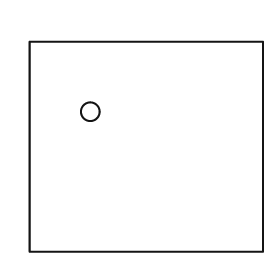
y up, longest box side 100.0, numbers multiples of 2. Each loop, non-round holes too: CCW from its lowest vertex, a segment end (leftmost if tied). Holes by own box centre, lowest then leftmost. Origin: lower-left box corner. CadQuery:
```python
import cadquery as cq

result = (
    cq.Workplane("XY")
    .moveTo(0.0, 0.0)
    .lineTo(100.0, 0.0)
    .lineTo(100.0, 90.0)
    .lineTo(0.0, 90.0)
    .close()
    .moveTo(26.0, 60.0)
    .circle(4.0)
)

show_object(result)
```